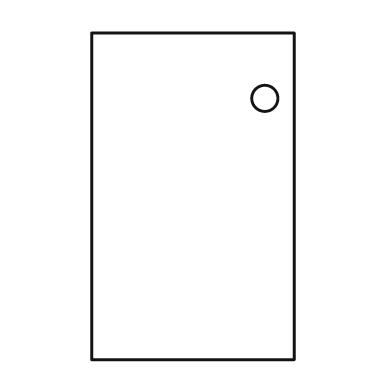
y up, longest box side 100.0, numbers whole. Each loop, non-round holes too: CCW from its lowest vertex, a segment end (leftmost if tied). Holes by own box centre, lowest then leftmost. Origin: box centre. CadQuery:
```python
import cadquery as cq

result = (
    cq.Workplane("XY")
    .moveTo(-31.0, -50.0)
    .lineTo(31.0, -50.0)
    .lineTo(31.0, 50.0)
    .lineTo(-31.0, 50.0)
    .close()
    .moveTo(22.0, 30.0)
    .circle(4.0)
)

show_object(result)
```